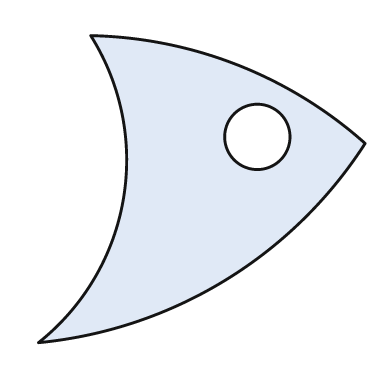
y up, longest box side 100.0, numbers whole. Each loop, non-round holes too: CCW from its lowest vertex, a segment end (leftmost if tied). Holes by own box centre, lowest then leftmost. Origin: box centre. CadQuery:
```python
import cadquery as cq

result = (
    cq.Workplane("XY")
    .moveTo(-50.0, -47.0)
    .threePointArc((7.0, -28.0), (50.0, 14.0))
    .threePointArc((11.0, 38.0), (-34.0, 47.0))
    .threePointArc((-24.0, -3.0), (-50.0, -47.0))
    .close()
    .moveTo(17.0, 16.0)
    .circle(10.0)
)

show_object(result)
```